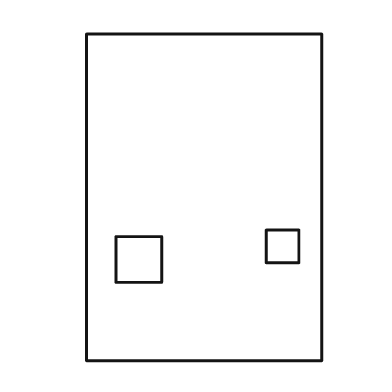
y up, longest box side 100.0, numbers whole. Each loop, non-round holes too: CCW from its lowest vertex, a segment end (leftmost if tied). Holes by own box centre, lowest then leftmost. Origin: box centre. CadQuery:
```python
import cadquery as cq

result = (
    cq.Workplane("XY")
    .moveTo(-36.0, -50.0)
    .lineTo(36.0, -50.0)
    .lineTo(36.0, 50.0)
    .lineTo(-36.0, 50.0)
    .close()
    .moveTo(-27.0, -26.0)
    .lineTo(-13.0, -26.0)
    .lineTo(-13.0, -12.0)
    .lineTo(-27.0, -12.0)
    .close()
    .moveTo(19.0, -20.0)
    .lineTo(29.0, -20.0)
    .lineTo(29.0, -10.0)
    .lineTo(19.0, -10.0)
    .close()
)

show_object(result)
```